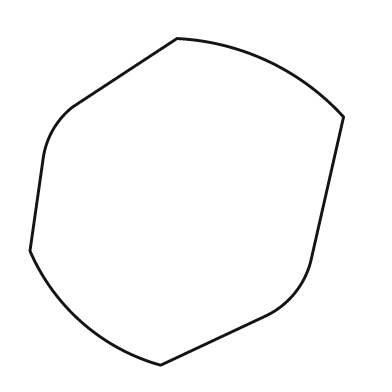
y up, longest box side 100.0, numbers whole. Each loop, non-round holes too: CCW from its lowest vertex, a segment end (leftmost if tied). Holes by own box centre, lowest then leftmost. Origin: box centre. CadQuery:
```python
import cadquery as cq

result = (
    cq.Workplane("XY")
    .moveTo(-8.0, -50.0)
    .lineTo(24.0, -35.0)
    .threePointArc((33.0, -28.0), (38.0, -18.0))
    .lineTo(48.0, 26.0)
    .threePointArc((25.0, 43.0), (-3.0, 50.0))
    .lineTo(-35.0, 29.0)
    .threePointArc((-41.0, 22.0), (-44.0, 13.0))
    .lineTo(-48.0, -15.0)
    .threePointArc((-32.0, -37.0), (-8.0, -50.0))
    .close()
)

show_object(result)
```